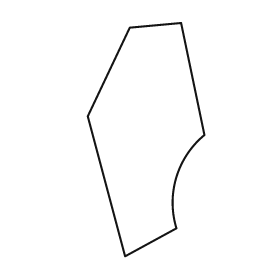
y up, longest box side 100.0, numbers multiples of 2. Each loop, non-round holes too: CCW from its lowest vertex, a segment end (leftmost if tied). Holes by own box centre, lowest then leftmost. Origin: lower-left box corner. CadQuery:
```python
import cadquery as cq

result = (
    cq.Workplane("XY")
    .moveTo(16.0, 0.0)
    .lineTo(38.0, 12.0)
    .threePointArc((38.0, 34.0), (50.0, 52.0))
    .lineTo(40.0, 100.0)
    .lineTo(18.0, 98.0)
    .lineTo(0.0, 60.0)
    .close()
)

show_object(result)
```